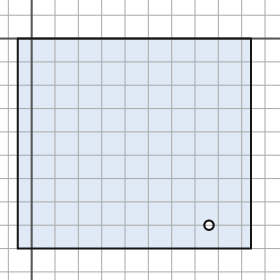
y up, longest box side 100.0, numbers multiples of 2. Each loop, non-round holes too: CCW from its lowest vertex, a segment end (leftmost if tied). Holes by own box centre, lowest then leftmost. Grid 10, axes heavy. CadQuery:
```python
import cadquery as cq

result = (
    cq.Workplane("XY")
    .moveTo(-6.0, -90.0)
    .lineTo(94.0, -90.0)
    .lineTo(94.0, 0.0)
    .lineTo(-6.0, 0.0)
    .close()
    .moveTo(76.0, -80.0)
    .circle(2.0)
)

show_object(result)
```